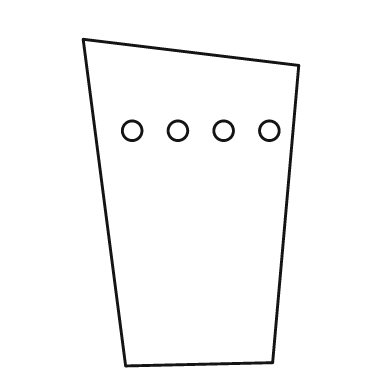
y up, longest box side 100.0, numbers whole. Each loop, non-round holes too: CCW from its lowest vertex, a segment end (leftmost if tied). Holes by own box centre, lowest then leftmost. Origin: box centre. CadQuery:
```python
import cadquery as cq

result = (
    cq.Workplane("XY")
    .moveTo(-20.0, -50.0)
    .lineTo(25.0, -49.0)
    .lineTo(33.0, 42.0)
    .lineTo(-33.0, 50.0)
    .close()
    .moveTo(-18.0, 22.0)
    .circle(3.0)
    .moveTo(-4.0, 22.0)
    .circle(3.0)
    .moveTo(10.0, 22.0)
    .circle(3.0)
    .moveTo(24.0, 22.0)
    .circle(3.0)
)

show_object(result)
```